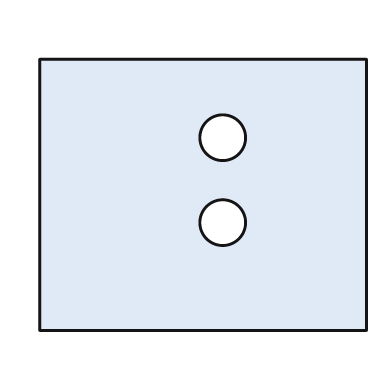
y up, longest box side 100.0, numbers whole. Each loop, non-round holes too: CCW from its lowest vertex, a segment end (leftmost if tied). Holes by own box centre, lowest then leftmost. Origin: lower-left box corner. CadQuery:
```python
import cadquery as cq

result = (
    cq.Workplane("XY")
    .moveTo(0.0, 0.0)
    .lineTo(100.0, 0.0)
    .lineTo(100.0, 83.0)
    .lineTo(0.0, 83.0)
    .close()
    .moveTo(56.0, 33.0)
    .circle(7.0)
    .moveTo(56.0, 59.0)
    .circle(7.0)
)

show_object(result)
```